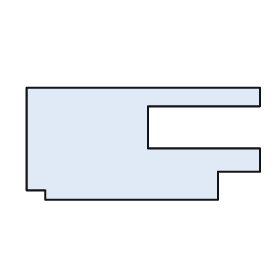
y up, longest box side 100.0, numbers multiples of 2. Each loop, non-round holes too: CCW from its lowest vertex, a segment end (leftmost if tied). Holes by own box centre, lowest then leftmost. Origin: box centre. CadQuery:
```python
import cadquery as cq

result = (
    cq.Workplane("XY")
    .moveTo(-42.0, -24.0)
    .lineTo(32.0, -24.0)
    .lineTo(32.0, -12.0)
    .lineTo(50.0, -12.0)
    .lineTo(50.0, -2.0)
    .lineTo(2.0, -2.0)
    .lineTo(2.0, 16.0)
    .lineTo(50.0, 16.0)
    .lineTo(50.0, 24.0)
    .lineTo(-50.0, 24.0)
    .lineTo(-50.0, -20.0)
    .lineTo(-42.0, -20.0)
    .close()
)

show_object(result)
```